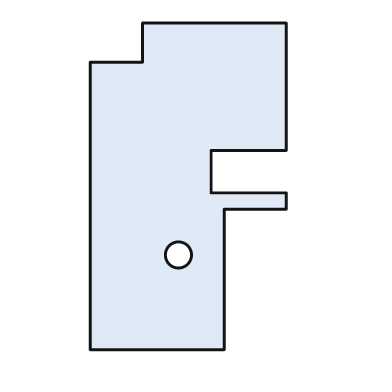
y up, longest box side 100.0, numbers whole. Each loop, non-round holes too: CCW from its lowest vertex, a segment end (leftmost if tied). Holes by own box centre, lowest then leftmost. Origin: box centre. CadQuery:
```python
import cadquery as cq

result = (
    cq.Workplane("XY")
    .moveTo(-30.0, -50.0)
    .lineTo(11.0, -50.0)
    .lineTo(11.0, -7.0)
    .lineTo(30.0, -7.0)
    .lineTo(30.0, -2.0)
    .lineTo(7.0, -2.0)
    .lineTo(7.0, 11.0)
    .lineTo(30.0, 11.0)
    .lineTo(30.0, 50.0)
    .lineTo(-14.0, 50.0)
    .lineTo(-14.0, 38.0)
    .lineTo(-30.0, 38.0)
    .close()
    .moveTo(-3.0, -21.0)
    .circle(4.0)
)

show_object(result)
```